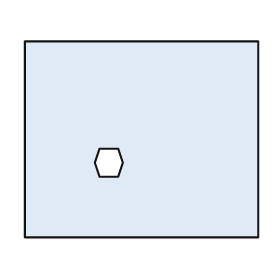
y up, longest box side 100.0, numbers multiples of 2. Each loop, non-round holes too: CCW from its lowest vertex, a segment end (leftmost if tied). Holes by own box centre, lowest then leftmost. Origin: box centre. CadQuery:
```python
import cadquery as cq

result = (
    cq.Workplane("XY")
    .moveTo(-50.0, -42.0)
    .lineTo(50.0, -42.0)
    .lineTo(50.0, 42.0)
    .lineTo(-50.0, 42.0)
    .close()
    .moveTo(-18.0, -16.0)
    .lineTo(-10.0, -16.0)
    .lineTo(-8.0, -10.0)
    .lineTo(-10.0, -4.0)
    .lineTo(-18.0, -4.0)
    .lineTo(-20.0, -10.0)
    .close()
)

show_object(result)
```